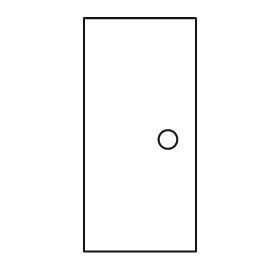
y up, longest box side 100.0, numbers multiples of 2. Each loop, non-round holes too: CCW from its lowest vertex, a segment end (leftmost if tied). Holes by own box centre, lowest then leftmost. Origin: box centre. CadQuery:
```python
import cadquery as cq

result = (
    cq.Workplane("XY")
    .moveTo(-24.0, -50.0)
    .lineTo(24.0, -50.0)
    .lineTo(24.0, 50.0)
    .lineTo(-24.0, 50.0)
    .close()
    .moveTo(12.0, -2.0)
    .circle(4.0)
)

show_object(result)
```